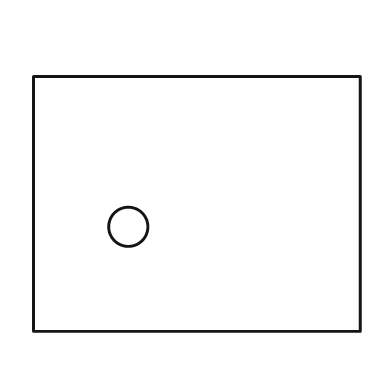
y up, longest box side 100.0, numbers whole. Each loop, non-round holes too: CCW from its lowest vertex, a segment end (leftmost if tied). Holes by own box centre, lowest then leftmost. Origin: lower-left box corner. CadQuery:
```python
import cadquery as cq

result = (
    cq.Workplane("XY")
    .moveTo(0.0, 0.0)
    .lineTo(100.0, 0.0)
    .lineTo(100.0, 78.0)
    .lineTo(0.0, 78.0)
    .close()
    .moveTo(29.0, 32.0)
    .circle(6.0)
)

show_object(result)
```